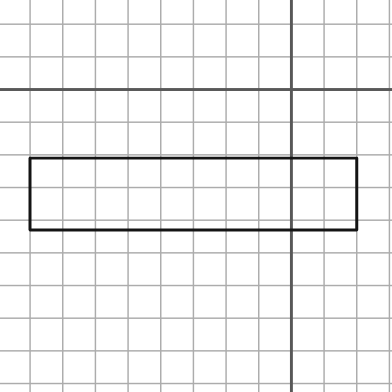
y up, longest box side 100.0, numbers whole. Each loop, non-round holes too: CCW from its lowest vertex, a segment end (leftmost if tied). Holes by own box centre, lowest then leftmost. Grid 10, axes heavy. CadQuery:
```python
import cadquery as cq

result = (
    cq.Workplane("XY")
    .moveTo(-80.0, -43.0)
    .lineTo(20.0, -43.0)
    .lineTo(20.0, -21.0)
    .lineTo(-80.0, -21.0)
    .close()
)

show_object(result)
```